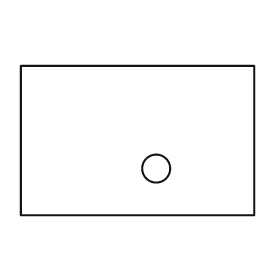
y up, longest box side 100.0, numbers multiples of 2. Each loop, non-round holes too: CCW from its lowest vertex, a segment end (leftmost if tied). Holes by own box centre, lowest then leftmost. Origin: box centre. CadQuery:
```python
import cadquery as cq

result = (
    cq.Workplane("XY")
    .moveTo(-50.0, -32.0)
    .lineTo(50.0, -32.0)
    .lineTo(50.0, 32.0)
    .lineTo(-50.0, 32.0)
    .close()
    .moveTo(8.0, -12.0)
    .circle(6.0)
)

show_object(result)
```